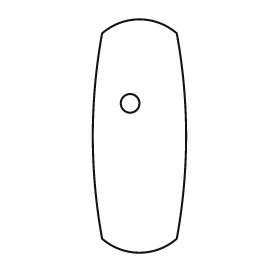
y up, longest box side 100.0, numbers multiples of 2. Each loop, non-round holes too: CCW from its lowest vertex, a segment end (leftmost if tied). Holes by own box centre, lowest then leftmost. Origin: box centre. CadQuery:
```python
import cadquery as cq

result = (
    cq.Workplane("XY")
    .moveTo(-16.0, -44.0)
    .threePointArc((0.0, -50.0), (16.0, -44.0))
    .threePointArc((20.0, 0.0), (16.0, 44.0))
    .threePointArc((0.0, 50.0), (-16.0, 44.0))
    .threePointArc((-20.0, 0.0), (-16.0, -44.0))
    .close()
    .moveTo(-4.0, 14.0)
    .circle(4.0)
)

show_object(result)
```